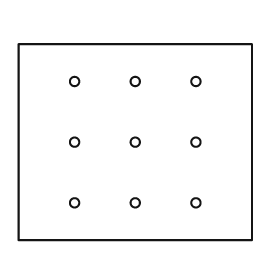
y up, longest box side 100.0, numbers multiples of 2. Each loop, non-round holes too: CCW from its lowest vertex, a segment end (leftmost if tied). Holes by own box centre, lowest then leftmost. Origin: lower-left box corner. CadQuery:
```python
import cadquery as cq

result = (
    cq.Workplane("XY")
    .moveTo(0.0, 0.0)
    .lineTo(100.0, 0.0)
    .lineTo(100.0, 84.0)
    .lineTo(0.0, 84.0)
    .close()
    .moveTo(24.0, 16.0)
    .circle(2.0)
    .moveTo(50.0, 16.0)
    .circle(2.0)
    .moveTo(76.0, 16.0)
    .circle(2.0)
    .moveTo(24.0, 42.0)
    .circle(2.0)
    .moveTo(50.0, 42.0)
    .circle(2.0)
    .moveTo(76.0, 42.0)
    .circle(2.0)
    .moveTo(24.0, 68.0)
    .circle(2.0)
    .moveTo(50.0, 68.0)
    .circle(2.0)
    .moveTo(76.0, 68.0)
    .circle(2.0)
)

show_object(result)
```